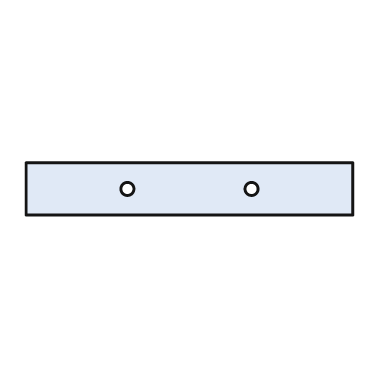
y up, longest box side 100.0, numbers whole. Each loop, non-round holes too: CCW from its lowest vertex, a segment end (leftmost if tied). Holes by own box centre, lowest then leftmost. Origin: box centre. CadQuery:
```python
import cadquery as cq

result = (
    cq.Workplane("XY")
    .moveTo(-50.0, -8.0)
    .lineTo(50.0, -8.0)
    .lineTo(50.0, 8.0)
    .lineTo(-50.0, 8.0)
    .close()
    .moveTo(-19.0, 0.0)
    .circle(2.0)
    .moveTo(19.0, 0.0)
    .circle(2.0)
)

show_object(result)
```